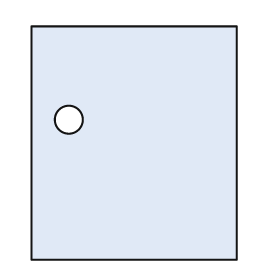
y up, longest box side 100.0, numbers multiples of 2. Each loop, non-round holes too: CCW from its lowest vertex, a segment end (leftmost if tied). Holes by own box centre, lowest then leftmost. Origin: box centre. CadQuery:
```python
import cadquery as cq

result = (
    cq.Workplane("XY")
    .moveTo(-44.0, -50.0)
    .lineTo(44.0, -50.0)
    .lineTo(44.0, 50.0)
    .lineTo(-44.0, 50.0)
    .close()
    .moveTo(-28.0, 10.0)
    .circle(6.0)
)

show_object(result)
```